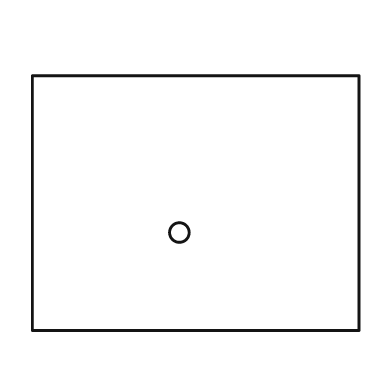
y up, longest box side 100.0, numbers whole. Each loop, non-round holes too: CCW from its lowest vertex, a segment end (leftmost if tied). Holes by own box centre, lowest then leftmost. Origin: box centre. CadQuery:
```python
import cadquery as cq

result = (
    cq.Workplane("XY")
    .moveTo(-50.0, -39.0)
    .lineTo(50.0, -39.0)
    .lineTo(50.0, 39.0)
    .lineTo(-50.0, 39.0)
    .close()
    .moveTo(-5.0, -9.0)
    .circle(3.0)
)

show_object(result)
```